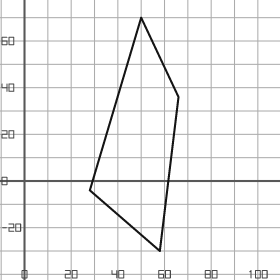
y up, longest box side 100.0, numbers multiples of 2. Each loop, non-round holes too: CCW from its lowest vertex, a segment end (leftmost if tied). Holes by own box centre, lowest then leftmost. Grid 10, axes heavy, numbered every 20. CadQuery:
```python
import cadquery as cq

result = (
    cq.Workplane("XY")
    .moveTo(58.0, -30.0)
    .lineTo(66.0, 36.0)
    .lineTo(50.0, 70.0)
    .lineTo(28.0, -4.0)
    .close()
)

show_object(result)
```